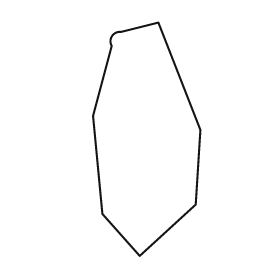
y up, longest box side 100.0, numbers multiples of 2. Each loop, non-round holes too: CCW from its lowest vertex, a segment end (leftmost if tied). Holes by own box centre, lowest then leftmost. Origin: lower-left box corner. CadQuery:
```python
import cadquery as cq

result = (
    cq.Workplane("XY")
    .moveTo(20.0, 0.0)
    .lineTo(44.0, 22.0)
    .lineTo(46.0, 54.0)
    .lineTo(28.0, 100.0)
    .lineTo(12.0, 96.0)
    .threePointArc((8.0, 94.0), (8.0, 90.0))
    .lineTo(0.0, 60.0)
    .lineTo(4.0, 18.0)
    .close()
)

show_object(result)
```